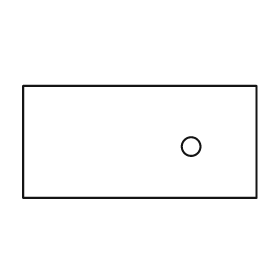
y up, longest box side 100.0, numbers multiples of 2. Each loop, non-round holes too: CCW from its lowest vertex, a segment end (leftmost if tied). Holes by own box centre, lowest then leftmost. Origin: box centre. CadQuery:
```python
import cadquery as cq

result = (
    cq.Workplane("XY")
    .moveTo(-50.0, -24.0)
    .lineTo(50.0, -24.0)
    .lineTo(50.0, 24.0)
    .lineTo(-50.0, 24.0)
    .close()
    .moveTo(22.0, -2.0)
    .circle(4.0)
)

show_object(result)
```